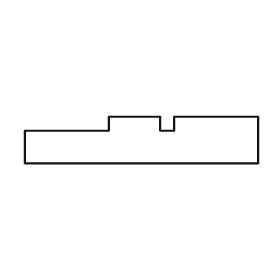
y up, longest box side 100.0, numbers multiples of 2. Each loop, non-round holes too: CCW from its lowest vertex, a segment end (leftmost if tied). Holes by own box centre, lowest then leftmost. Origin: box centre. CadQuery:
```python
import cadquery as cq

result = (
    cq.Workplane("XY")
    .moveTo(-50.0, -10.0)
    .lineTo(50.0, -10.0)
    .lineTo(50.0, 10.0)
    .lineTo(14.0, 10.0)
    .lineTo(14.0, 4.0)
    .lineTo(8.0, 4.0)
    .lineTo(8.0, 10.0)
    .lineTo(-14.0, 10.0)
    .lineTo(-14.0, 4.0)
    .lineTo(-50.0, 4.0)
    .close()
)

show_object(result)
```